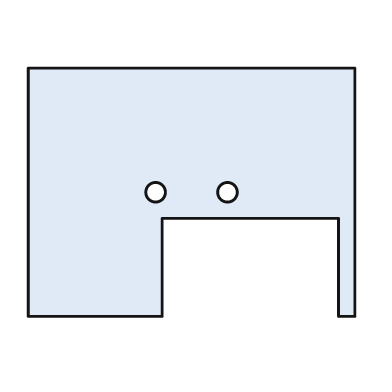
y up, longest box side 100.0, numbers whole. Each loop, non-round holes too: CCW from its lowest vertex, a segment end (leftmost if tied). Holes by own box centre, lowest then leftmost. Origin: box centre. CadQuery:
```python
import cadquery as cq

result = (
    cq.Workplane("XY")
    .moveTo(-50.0, -38.0)
    .lineTo(-9.0, -38.0)
    .lineTo(-9.0, -8.0)
    .lineTo(45.0, -8.0)
    .lineTo(45.0, -38.0)
    .lineTo(50.0, -38.0)
    .lineTo(50.0, 38.0)
    .lineTo(-50.0, 38.0)
    .close()
    .moveTo(-11.0, 0.0)
    .circle(3.0)
    .moveTo(11.0, 0.0)
    .circle(3.0)
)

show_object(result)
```